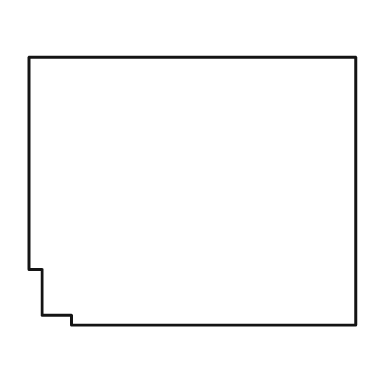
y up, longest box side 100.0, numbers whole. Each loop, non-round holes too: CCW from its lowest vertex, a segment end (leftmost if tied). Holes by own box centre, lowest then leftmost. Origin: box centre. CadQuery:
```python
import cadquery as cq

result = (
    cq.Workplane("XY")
    .moveTo(-37.0, -41.0)
    .lineTo(50.0, -41.0)
    .lineTo(50.0, 41.0)
    .lineTo(-50.0, 41.0)
    .lineTo(-50.0, -24.0)
    .lineTo(-46.0, -24.0)
    .lineTo(-46.0, -38.0)
    .lineTo(-37.0, -38.0)
    .close()
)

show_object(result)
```